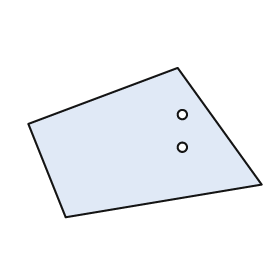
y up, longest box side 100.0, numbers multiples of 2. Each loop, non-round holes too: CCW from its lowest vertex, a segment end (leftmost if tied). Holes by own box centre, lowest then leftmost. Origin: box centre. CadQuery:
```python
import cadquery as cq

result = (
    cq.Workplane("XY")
    .moveTo(-34.0, -32.0)
    .lineTo(50.0, -18.0)
    .lineTo(14.0, 32.0)
    .lineTo(-50.0, 8.0)
    .close()
    .moveTo(16.0, -2.0)
    .circle(2.0)
    .moveTo(16.0, 12.0)
    .circle(2.0)
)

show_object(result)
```